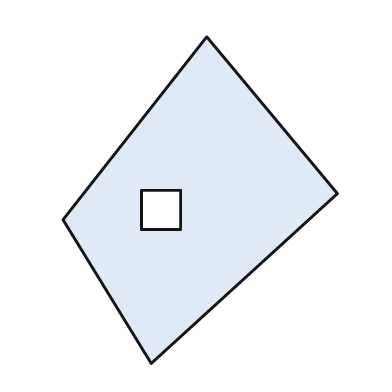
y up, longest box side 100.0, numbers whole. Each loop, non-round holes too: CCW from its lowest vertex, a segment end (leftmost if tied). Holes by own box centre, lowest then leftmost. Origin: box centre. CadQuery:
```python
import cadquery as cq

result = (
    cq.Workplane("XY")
    .moveTo(-15.0, -50.0)
    .lineTo(42.0, 2.0)
    .lineTo(2.0, 50.0)
    .lineTo(-42.0, -6.0)
    .close()
    .moveTo(-18.0, -9.0)
    .lineTo(-6.0, -9.0)
    .lineTo(-6.0, 3.0)
    .lineTo(-18.0, 3.0)
    .close()
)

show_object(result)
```